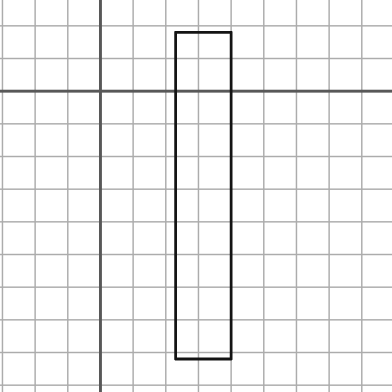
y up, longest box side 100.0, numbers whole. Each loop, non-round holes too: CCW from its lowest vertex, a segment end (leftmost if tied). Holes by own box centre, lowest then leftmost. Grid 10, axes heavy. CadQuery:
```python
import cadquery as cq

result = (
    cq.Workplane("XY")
    .moveTo(23.0, -82.0)
    .lineTo(40.0, -82.0)
    .lineTo(40.0, 18.0)
    .lineTo(23.0, 18.0)
    .close()
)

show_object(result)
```